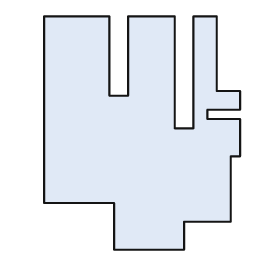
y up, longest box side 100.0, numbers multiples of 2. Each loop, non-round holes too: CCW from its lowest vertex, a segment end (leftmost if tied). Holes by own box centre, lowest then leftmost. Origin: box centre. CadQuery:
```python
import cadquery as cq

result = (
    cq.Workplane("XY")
    .moveTo(-12.0, -50.0)
    .lineTo(18.0, -50.0)
    .lineTo(18.0, -38.0)
    .lineTo(38.0, -38.0)
    .lineTo(38.0, -10.0)
    .lineTo(42.0, -10.0)
    .lineTo(42.0, 6.0)
    .lineTo(28.0, 6.0)
    .lineTo(28.0, 10.0)
    .lineTo(42.0, 10.0)
    .lineTo(42.0, 18.0)
    .lineTo(32.0, 18.0)
    .lineTo(32.0, 50.0)
    .lineTo(22.0, 50.0)
    .lineTo(22.0, 2.0)
    .lineTo(14.0, 2.0)
    .lineTo(14.0, 50.0)
    .lineTo(-6.0, 50.0)
    .lineTo(-6.0, 16.0)
    .lineTo(-14.0, 16.0)
    .lineTo(-14.0, 50.0)
    .lineTo(-42.0, 50.0)
    .lineTo(-42.0, -30.0)
    .lineTo(-12.0, -30.0)
    .close()
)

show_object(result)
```